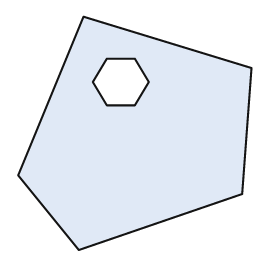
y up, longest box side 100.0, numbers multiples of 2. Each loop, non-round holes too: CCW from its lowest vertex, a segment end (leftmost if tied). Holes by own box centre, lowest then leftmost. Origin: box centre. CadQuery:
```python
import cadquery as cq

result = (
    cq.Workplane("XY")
    .moveTo(-24.0, -50.0)
    .lineTo(46.0, -26.0)
    .lineTo(50.0, 28.0)
    .lineTo(-22.0, 50.0)
    .lineTo(-50.0, -18.0)
    .close()
    .moveTo(-12.0, 12.0)
    .lineTo(0.0, 12.0)
    .lineTo(6.0, 22.0)
    .lineTo(0.0, 32.0)
    .lineTo(-12.0, 32.0)
    .lineTo(-18.0, 22.0)
    .close()
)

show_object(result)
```